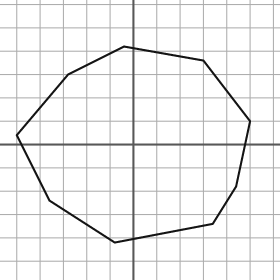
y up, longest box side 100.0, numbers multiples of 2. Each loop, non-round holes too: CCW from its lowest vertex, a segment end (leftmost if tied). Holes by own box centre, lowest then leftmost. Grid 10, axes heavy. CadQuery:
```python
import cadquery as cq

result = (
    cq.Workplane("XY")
    .moveTo(-8.0, -42.0)
    .lineTo(34.0, -34.0)
    .lineTo(44.0, -18.0)
    .lineTo(50.0, 10.0)
    .lineTo(30.0, 36.0)
    .lineTo(-4.0, 42.0)
    .lineTo(-28.0, 30.0)
    .lineTo(-50.0, 4.0)
    .lineTo(-36.0, -24.0)
    .close()
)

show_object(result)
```